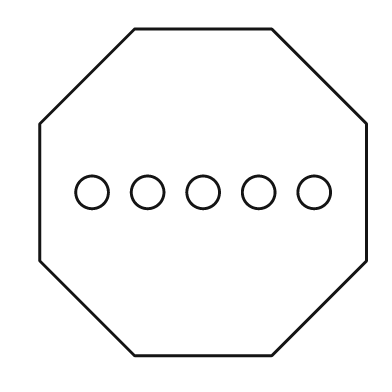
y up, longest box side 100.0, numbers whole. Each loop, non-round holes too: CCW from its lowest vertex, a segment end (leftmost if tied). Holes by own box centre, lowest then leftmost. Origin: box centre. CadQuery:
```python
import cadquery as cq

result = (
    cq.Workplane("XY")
    .moveTo(-21.0, -50.0)
    .lineTo(21.0, -50.0)
    .lineTo(50.0, -21.0)
    .lineTo(50.0, 21.0)
    .lineTo(21.0, 50.0)
    .lineTo(-21.0, 50.0)
    .lineTo(-50.0, 21.0)
    .lineTo(-50.0, -21.0)
    .close()
    .moveTo(-34.0, 0.0)
    .circle(5.0)
    .moveTo(-17.0, 0.0)
    .circle(5.0)
    .moveTo(0.0, 0.0)
    .circle(5.0)
    .moveTo(17.0, 0.0)
    .circle(5.0)
    .moveTo(34.0, 0.0)
    .circle(5.0)
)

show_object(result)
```